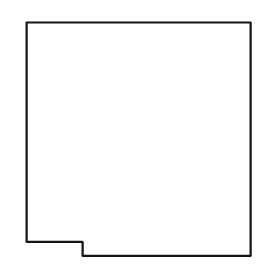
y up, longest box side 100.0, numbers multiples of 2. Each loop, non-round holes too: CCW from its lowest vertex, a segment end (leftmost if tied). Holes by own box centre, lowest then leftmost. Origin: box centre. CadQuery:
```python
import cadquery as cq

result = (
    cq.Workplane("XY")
    .moveTo(-24.0, -50.0)
    .lineTo(48.0, -50.0)
    .lineTo(48.0, 50.0)
    .lineTo(-48.0, 50.0)
    .lineTo(-48.0, -44.0)
    .lineTo(-24.0, -44.0)
    .close()
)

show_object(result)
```